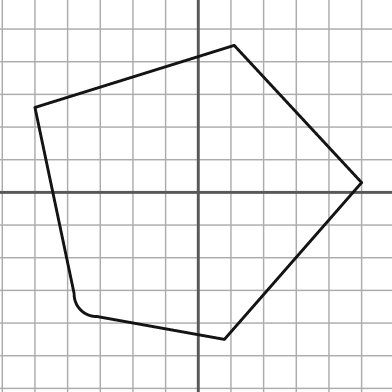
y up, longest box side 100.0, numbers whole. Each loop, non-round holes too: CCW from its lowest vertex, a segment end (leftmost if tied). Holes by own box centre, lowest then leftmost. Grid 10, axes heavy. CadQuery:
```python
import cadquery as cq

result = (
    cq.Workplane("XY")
    .moveTo(8.0, -45.0)
    .lineTo(50.0, 3.0)
    .lineTo(11.0, 45.0)
    .lineTo(-50.0, 26.0)
    .lineTo(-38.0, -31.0)
    .threePointArc((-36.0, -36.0), (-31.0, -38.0))
    .close()
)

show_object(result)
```